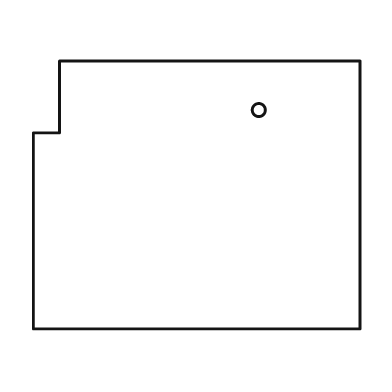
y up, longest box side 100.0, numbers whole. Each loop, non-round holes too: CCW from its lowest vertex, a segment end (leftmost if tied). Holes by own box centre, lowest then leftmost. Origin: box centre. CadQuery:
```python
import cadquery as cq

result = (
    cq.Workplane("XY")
    .moveTo(-50.0, -41.0)
    .lineTo(50.0, -41.0)
    .lineTo(50.0, 41.0)
    .lineTo(-42.0, 41.0)
    .lineTo(-42.0, 19.0)
    .lineTo(-50.0, 19.0)
    .close()
    .moveTo(19.0, 26.0)
    .circle(2.0)
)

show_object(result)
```